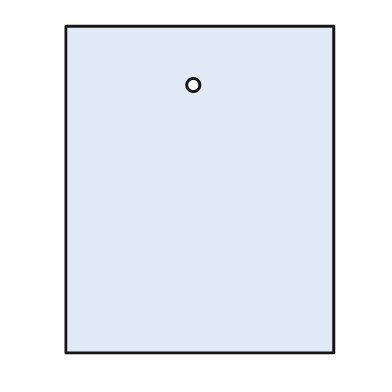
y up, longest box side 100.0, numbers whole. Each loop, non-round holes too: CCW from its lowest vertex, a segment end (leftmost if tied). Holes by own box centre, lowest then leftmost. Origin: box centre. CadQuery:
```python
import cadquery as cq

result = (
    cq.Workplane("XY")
    .moveTo(-41.0, -50.0)
    .lineTo(41.0, -50.0)
    .lineTo(41.0, 50.0)
    .lineTo(-41.0, 50.0)
    .close()
    .moveTo(-2.0, 32.0)
    .circle(2.0)
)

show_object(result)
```